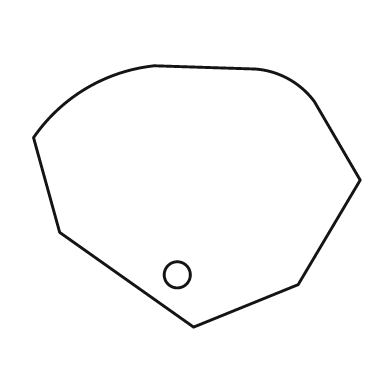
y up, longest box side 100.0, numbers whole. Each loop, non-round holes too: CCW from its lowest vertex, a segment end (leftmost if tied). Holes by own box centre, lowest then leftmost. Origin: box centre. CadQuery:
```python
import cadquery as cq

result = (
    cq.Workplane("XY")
    .moveTo(-1.0, -40.0)
    .lineTo(31.0, -27.0)
    .lineTo(50.0, 5.0)
    .lineTo(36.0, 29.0)
    .threePointArc((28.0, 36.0), (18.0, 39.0))
    .lineTo(-13.0, 40.0)
    .threePointArc((-34.0, 33.0), (-50.0, 18.0))
    .lineTo(-42.0, -11.0)
    .close()
    .moveTo(-6.0, -24.0)
    .circle(4.0)
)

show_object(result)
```